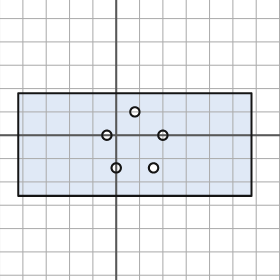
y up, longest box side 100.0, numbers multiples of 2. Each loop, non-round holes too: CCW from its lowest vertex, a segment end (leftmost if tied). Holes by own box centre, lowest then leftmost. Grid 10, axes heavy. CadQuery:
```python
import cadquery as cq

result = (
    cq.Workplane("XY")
    .moveTo(-42.0, -26.0)
    .lineTo(58.0, -26.0)
    .lineTo(58.0, 18.0)
    .lineTo(-42.0, 18.0)
    .close()
    .moveTo(0.0, -14.0)
    .circle(2.0)
    .moveTo(16.0, -14.0)
    .circle(2.0)
    .moveTo(-4.0, 0.0)
    .circle(2.0)
    .moveTo(20.0, 0.0)
    .circle(2.0)
    .moveTo(8.0, 10.0)
    .circle(2.0)
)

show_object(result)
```